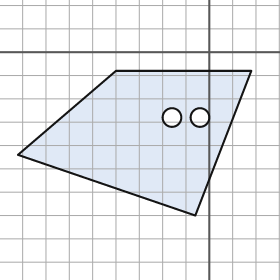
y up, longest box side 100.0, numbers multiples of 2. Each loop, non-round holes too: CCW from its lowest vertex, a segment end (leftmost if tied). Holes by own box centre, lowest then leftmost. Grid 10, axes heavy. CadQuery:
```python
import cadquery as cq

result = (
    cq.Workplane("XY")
    .moveTo(-6.0, -70.0)
    .lineTo(18.0, -8.0)
    .lineTo(-40.0, -8.0)
    .lineTo(-82.0, -44.0)
    .close()
    .moveTo(-16.0, -28.0)
    .circle(4.0)
    .moveTo(-4.0, -28.0)
    .circle(4.0)
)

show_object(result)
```